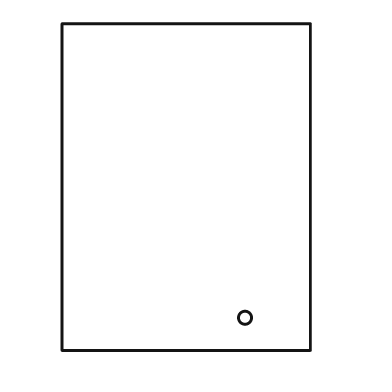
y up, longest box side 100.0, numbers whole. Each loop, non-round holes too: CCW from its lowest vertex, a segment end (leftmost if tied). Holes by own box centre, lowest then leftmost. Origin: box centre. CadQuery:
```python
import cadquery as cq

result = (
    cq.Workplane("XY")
    .moveTo(-38.0, -50.0)
    .lineTo(38.0, -50.0)
    .lineTo(38.0, 50.0)
    .lineTo(-38.0, 50.0)
    .close()
    .moveTo(18.0, -40.0)
    .circle(2.0)
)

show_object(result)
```